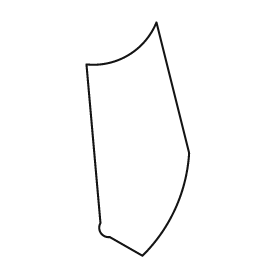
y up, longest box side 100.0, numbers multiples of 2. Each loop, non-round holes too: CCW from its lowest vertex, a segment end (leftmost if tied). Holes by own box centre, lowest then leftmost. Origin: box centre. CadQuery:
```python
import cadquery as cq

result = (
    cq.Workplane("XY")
    .moveTo(2.0, -50.0)
    .threePointArc((16.0, -30.0), (22.0, -6.0))
    .lineTo(8.0, 50.0)
    .threePointArc((-4.0, 36.0), (-22.0, 32.0))
    .lineTo(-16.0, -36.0)
    .threePointArc((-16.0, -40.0), (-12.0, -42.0))
    .close()
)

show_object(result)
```